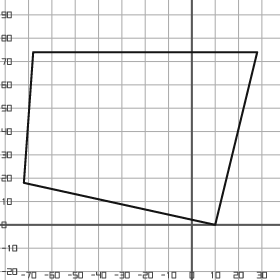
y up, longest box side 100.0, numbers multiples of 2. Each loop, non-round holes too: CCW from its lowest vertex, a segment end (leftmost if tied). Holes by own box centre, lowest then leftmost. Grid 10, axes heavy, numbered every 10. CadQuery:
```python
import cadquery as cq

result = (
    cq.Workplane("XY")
    .moveTo(10.0, 0.0)
    .lineTo(28.0, 74.0)
    .lineTo(-68.0, 74.0)
    .lineTo(-72.0, 18.0)
    .close()
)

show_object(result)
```